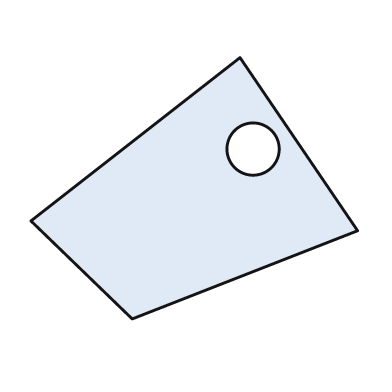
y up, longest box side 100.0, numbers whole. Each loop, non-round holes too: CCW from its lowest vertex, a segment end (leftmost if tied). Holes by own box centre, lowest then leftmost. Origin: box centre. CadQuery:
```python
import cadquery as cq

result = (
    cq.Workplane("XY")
    .moveTo(-19.0, -40.0)
    .lineTo(50.0, -13.0)
    .lineTo(14.0, 40.0)
    .lineTo(-50.0, -10.0)
    .close()
    .moveTo(18.0, 12.0)
    .circle(8.0)
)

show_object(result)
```